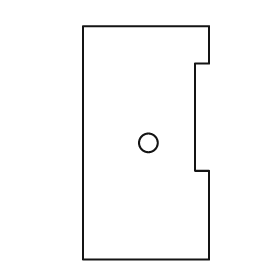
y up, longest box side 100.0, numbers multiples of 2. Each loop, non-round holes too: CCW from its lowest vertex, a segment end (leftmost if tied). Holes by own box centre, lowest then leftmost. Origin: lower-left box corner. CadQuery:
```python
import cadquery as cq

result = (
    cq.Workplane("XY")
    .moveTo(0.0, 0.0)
    .lineTo(54.0, 0.0)
    .lineTo(54.0, 38.0)
    .lineTo(48.0, 38.0)
    .lineTo(48.0, 84.0)
    .lineTo(54.0, 84.0)
    .lineTo(54.0, 100.0)
    .lineTo(0.0, 100.0)
    .close()
    .moveTo(28.0, 50.0)
    .circle(4.0)
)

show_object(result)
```